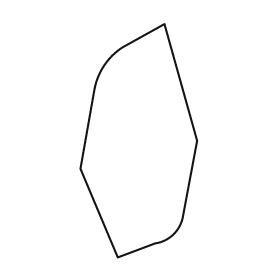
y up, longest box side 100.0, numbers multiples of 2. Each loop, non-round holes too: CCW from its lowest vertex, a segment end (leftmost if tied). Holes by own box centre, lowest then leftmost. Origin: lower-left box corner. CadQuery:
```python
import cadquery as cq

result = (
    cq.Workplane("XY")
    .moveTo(16.0, 0.0)
    .lineTo(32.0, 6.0)
    .threePointArc((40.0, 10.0), (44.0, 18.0))
    .lineTo(50.0, 50.0)
    .lineTo(36.0, 100.0)
    .lineTo(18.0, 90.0)
    .threePointArc((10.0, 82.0), (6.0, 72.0))
    .lineTo(0.0, 38.0)
    .close()
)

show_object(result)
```